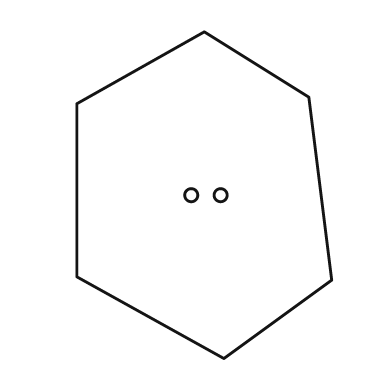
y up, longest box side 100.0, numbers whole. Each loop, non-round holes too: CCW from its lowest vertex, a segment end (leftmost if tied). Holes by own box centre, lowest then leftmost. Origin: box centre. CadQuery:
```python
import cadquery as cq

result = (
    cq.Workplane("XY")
    .moveTo(6.0, -50.0)
    .lineTo(39.0, -26.0)
    .lineTo(32.0, 30.0)
    .lineTo(0.0, 50.0)
    .lineTo(-39.0, 28.0)
    .lineTo(-39.0, -25.0)
    .close()
    .moveTo(-4.0, 0.0)
    .circle(2.0)
    .moveTo(5.0, 0.0)
    .circle(2.0)
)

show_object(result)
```